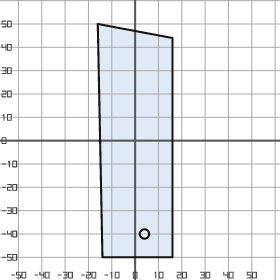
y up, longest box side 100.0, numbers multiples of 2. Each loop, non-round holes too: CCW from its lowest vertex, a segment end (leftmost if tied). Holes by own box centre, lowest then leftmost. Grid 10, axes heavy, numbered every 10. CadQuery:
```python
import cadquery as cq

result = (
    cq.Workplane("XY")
    .moveTo(-14.0, -50.0)
    .lineTo(16.0, -50.0)
    .lineTo(16.0, 44.0)
    .lineTo(-16.0, 50.0)
    .close()
    .moveTo(4.0, -40.0)
    .circle(2.0)
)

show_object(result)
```